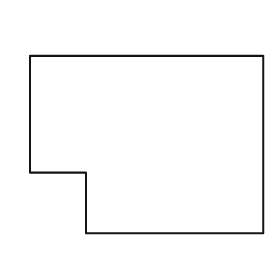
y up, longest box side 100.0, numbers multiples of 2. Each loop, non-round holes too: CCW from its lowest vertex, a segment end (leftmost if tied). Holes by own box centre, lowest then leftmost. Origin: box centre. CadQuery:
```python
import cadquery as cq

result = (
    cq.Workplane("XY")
    .moveTo(-26.0, -38.0)
    .lineTo(50.0, -38.0)
    .lineTo(50.0, 38.0)
    .lineTo(-50.0, 38.0)
    .lineTo(-50.0, -12.0)
    .lineTo(-26.0, -12.0)
    .close()
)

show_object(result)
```